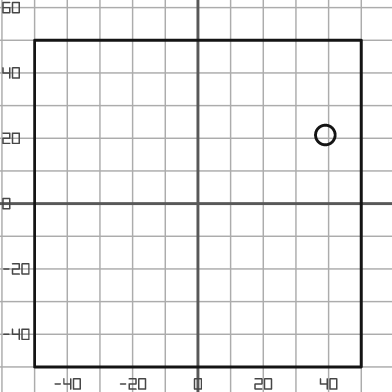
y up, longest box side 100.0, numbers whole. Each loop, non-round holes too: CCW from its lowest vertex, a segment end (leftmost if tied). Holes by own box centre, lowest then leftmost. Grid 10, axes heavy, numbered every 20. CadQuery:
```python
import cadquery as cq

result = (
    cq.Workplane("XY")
    .moveTo(-50.0, -50.0)
    .lineTo(50.0, -50.0)
    .lineTo(50.0, 50.0)
    .lineTo(-50.0, 50.0)
    .close()
    .moveTo(39.0, 21.0)
    .circle(3.0)
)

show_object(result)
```